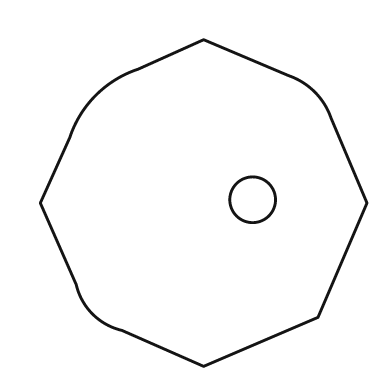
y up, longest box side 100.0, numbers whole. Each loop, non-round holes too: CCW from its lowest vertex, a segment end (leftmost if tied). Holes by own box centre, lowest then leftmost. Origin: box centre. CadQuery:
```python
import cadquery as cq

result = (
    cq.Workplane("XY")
    .moveTo(0.0, -50.0)
    .lineTo(35.0, -35.0)
    .lineTo(50.0, 0.0)
    .lineTo(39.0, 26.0)
    .threePointArc((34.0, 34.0), (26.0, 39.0))
    .lineTo(0.0, 50.0)
    .lineTo(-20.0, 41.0)
    .threePointArc((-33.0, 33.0), (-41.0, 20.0))
    .lineTo(-50.0, 0.0)
    .lineTo(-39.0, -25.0)
    .threePointArc((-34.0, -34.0), (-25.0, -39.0))
    .close()
    .moveTo(15.0, 1.0)
    .circle(7.0)
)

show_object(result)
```